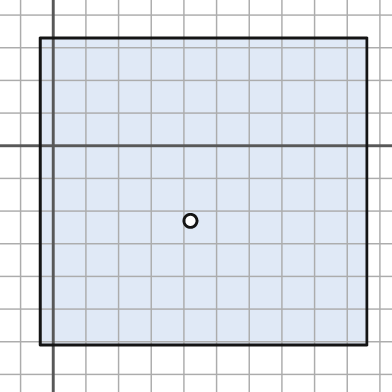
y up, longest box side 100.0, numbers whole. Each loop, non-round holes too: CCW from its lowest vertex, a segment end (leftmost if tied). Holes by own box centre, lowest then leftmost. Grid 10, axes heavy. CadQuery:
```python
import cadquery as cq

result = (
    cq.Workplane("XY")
    .moveTo(-4.0, -61.0)
    .lineTo(96.0, -61.0)
    .lineTo(96.0, 33.0)
    .lineTo(-4.0, 33.0)
    .close()
    .moveTo(42.0, -23.0)
    .circle(2.0)
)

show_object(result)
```